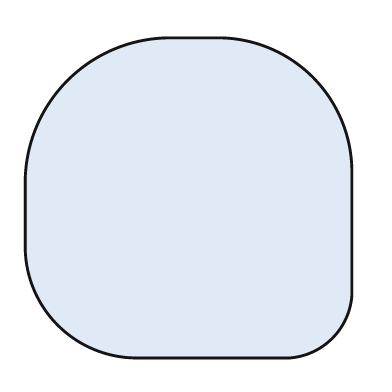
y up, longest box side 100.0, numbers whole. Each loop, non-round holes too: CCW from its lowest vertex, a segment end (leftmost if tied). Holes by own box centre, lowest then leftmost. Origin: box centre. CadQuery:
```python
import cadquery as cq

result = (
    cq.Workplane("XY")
    .moveTo(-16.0, -49.0)
    .lineTo(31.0, -49.0)
    .threePointArc((44.0, -43.0), (50.0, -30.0))
    .lineTo(50.0, 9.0)
    .threePointArc((38.0, 37.0), (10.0, 49.0))
    .lineTo(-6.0, 49.0)
    .threePointArc((-37.0, 36.0), (-50.0, 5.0))
    .lineTo(-50.0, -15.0)
    .threePointArc((-40.0, -39.0), (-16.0, -49.0))
    .close()
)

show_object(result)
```